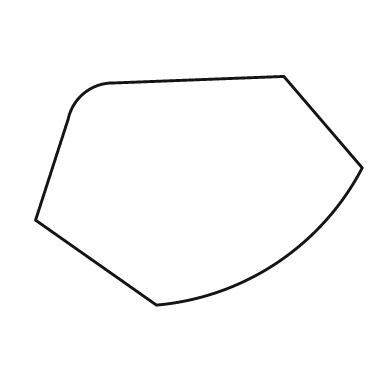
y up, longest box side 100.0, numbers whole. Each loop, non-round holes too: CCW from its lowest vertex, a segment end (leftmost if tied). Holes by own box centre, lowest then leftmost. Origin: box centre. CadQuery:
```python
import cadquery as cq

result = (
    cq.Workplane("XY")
    .moveTo(-13.0, -35.0)
    .threePointArc((24.0, -22.0), (50.0, 7.0))
    .lineTo(26.0, 35.0)
    .lineTo(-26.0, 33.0)
    .threePointArc((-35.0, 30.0), (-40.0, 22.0))
    .lineTo(-50.0, -9.0)
    .close()
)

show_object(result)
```